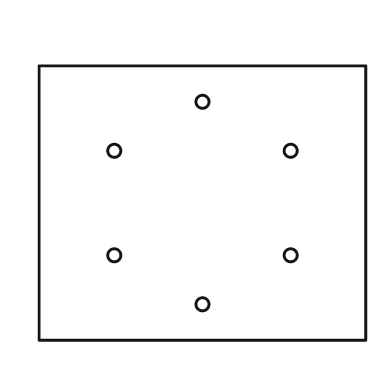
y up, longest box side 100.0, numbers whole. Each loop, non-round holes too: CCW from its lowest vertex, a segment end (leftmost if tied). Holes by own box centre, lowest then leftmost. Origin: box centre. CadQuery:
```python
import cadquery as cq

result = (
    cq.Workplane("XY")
    .moveTo(-50.0, -42.0)
    .lineTo(50.0, -42.0)
    .lineTo(50.0, 42.0)
    .lineTo(-50.0, 42.0)
    .close()
    .moveTo(0.0, -31.0)
    .circle(2.0)
    .moveTo(-27.0, -16.0)
    .circle(2.0)
    .moveTo(27.0, -16.0)
    .circle(2.0)
    .moveTo(-27.0, 16.0)
    .circle(2.0)
    .moveTo(27.0, 16.0)
    .circle(2.0)
    .moveTo(0.0, 31.0)
    .circle(2.0)
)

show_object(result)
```